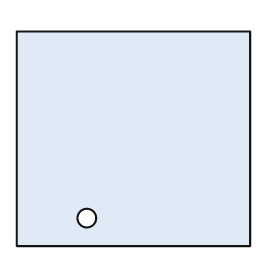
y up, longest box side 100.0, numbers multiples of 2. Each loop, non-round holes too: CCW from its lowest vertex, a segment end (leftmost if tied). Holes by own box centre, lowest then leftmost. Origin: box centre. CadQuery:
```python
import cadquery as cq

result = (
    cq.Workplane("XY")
    .moveTo(-50.0, -46.0)
    .lineTo(50.0, -46.0)
    .lineTo(50.0, 46.0)
    .lineTo(-50.0, 46.0)
    .close()
    .moveTo(-20.0, -34.0)
    .circle(4.0)
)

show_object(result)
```